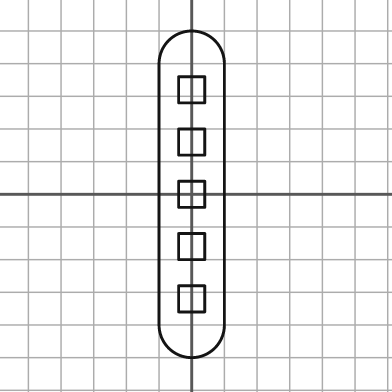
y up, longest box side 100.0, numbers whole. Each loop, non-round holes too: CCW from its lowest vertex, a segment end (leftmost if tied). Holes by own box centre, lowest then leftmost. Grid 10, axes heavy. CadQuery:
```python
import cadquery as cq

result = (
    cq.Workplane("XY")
    .moveTo(-10.0, -40.0)
    .threePointArc((0.0, -50.0), (10.0, -40.0))
    .lineTo(10.0, 40.0)
    .threePointArc((0.0, 50.0), (-10.0, 40.0))
    .close()
    .moveTo(-4.0, -36.0)
    .lineTo(4.0, -36.0)
    .lineTo(4.0, -28.0)
    .lineTo(-4.0, -28.0)
    .close()
    .moveTo(-4.0, -20.0)
    .lineTo(4.0, -20.0)
    .lineTo(4.0, -12.0)
    .lineTo(-4.0, -12.0)
    .close()
    .moveTo(-4.0, -4.0)
    .lineTo(4.0, -4.0)
    .lineTo(4.0, 4.0)
    .lineTo(-4.0, 4.0)
    .close()
    .moveTo(-4.0, 12.0)
    .lineTo(4.0, 12.0)
    .lineTo(4.0, 20.0)
    .lineTo(-4.0, 20.0)
    .close()
    .moveTo(-4.0, 28.0)
    .lineTo(4.0, 28.0)
    .lineTo(4.0, 36.0)
    .lineTo(-4.0, 36.0)
    .close()
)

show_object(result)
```